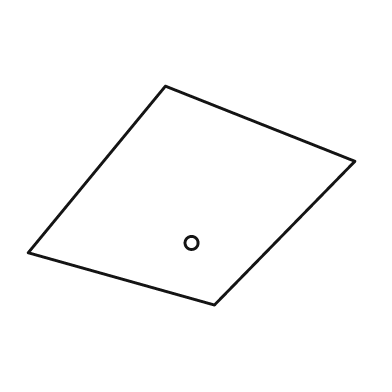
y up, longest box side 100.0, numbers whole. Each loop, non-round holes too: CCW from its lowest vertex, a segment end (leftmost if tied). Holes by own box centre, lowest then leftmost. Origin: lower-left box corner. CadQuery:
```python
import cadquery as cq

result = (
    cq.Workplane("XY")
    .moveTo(57.0, 0.0)
    .lineTo(100.0, 44.0)
    .lineTo(42.0, 67.0)
    .lineTo(0.0, 16.0)
    .close()
    .moveTo(50.0, 19.0)
    .circle(2.0)
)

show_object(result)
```